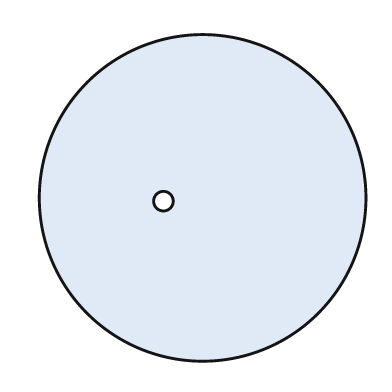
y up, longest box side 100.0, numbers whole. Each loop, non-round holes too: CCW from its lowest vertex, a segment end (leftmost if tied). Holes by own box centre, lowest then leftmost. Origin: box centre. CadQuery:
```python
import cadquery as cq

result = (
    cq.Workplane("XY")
    .moveTo(0.0, 0.0)
    .circle(50.0)
    .moveTo(-12.0, -1.0)
    .circle(3.0)
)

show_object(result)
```